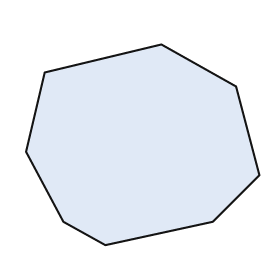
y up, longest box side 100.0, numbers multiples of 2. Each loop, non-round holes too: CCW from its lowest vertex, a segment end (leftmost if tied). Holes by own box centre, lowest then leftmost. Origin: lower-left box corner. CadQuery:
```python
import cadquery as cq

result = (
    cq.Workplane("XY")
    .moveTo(34.0, 0.0)
    .lineTo(80.0, 10.0)
    .lineTo(100.0, 30.0)
    .lineTo(90.0, 68.0)
    .lineTo(58.0, 86.0)
    .lineTo(8.0, 74.0)
    .lineTo(0.0, 40.0)
    .lineTo(16.0, 10.0)
    .close()
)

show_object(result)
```